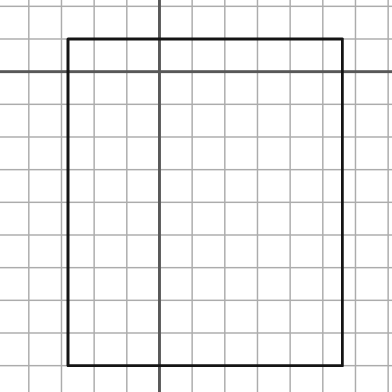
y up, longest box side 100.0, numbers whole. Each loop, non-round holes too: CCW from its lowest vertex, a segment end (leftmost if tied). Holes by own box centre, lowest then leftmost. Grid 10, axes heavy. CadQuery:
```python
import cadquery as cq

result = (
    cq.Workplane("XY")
    .moveTo(-28.0, -90.0)
    .lineTo(56.0, -90.0)
    .lineTo(56.0, 10.0)
    .lineTo(-28.0, 10.0)
    .close()
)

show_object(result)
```